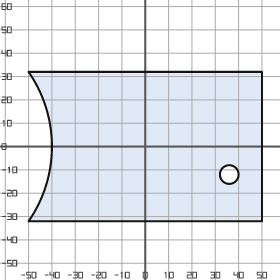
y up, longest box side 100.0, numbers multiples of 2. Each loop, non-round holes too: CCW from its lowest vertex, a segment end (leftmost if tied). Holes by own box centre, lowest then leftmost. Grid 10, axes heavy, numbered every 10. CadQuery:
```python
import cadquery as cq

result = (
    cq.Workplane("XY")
    .moveTo(-50.0, -32.0)
    .lineTo(50.0, -32.0)
    .lineTo(50.0, 32.0)
    .lineTo(-50.0, 32.0)
    .threePointArc((-40.0, 0.0), (-50.0, -32.0))
    .close()
    .moveTo(36.0, -12.0)
    .circle(4.0)
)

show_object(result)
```